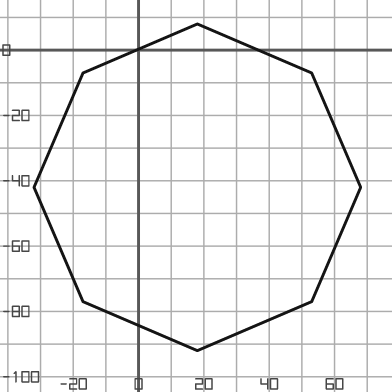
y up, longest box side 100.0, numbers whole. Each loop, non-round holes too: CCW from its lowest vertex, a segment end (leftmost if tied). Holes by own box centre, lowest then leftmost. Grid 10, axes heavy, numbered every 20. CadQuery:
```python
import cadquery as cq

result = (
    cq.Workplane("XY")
    .moveTo(18.0, -92.0)
    .lineTo(53.0, -77.0)
    .lineTo(68.0, -42.0)
    .lineTo(53.0, -7.0)
    .lineTo(18.0, 8.0)
    .lineTo(-17.0, -7.0)
    .lineTo(-32.0, -42.0)
    .lineTo(-17.0, -77.0)
    .close()
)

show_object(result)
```